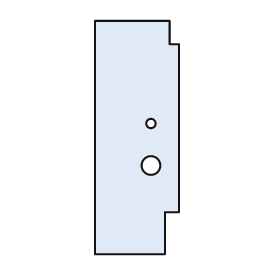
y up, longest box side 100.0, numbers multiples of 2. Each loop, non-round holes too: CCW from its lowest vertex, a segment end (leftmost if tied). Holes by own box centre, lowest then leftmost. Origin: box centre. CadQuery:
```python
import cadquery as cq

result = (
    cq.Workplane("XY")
    .moveTo(-18.0, -50.0)
    .lineTo(12.0, -50.0)
    .lineTo(12.0, -32.0)
    .lineTo(18.0, -32.0)
    .lineTo(18.0, 40.0)
    .lineTo(14.0, 40.0)
    .lineTo(14.0, 50.0)
    .lineTo(-18.0, 50.0)
    .close()
    .moveTo(6.0, -12.0)
    .circle(4.0)
    .moveTo(6.0, 6.0)
    .circle(2.0)
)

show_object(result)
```